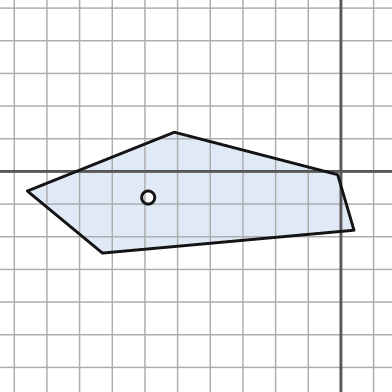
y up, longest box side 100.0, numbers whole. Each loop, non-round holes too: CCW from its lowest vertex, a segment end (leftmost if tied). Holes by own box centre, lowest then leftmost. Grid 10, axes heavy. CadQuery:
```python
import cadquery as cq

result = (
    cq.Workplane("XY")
    .moveTo(-73.0, -25.0)
    .lineTo(4.0, -18.0)
    .lineTo(-1.0, -1.0)
    .lineTo(-51.0, 12.0)
    .lineTo(-96.0, -6.0)
    .close()
    .moveTo(-59.0, -8.0)
    .circle(2.0)
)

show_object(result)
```